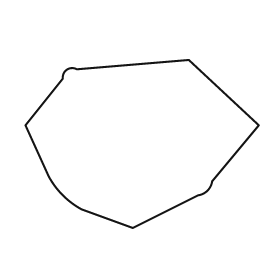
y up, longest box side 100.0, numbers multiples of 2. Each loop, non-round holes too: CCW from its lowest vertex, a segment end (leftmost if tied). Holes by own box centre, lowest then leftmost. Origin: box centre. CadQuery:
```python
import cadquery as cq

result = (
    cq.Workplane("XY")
    .moveTo(-4.0, -36.0)
    .lineTo(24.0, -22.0)
    .threePointArc((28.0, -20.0), (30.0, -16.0))
    .lineTo(50.0, 8.0)
    .lineTo(20.0, 36.0)
    .lineTo(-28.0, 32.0)
    .threePointArc((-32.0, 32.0), (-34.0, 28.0))
    .lineTo(-50.0, 8.0)
    .lineTo(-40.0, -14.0)
    .threePointArc((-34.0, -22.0), (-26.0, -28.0))
    .close()
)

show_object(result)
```